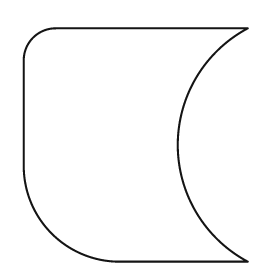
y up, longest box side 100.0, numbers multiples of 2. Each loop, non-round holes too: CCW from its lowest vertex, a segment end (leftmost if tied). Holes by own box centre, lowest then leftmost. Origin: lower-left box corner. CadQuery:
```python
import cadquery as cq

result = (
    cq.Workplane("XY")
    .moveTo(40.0, 0.0)
    .lineTo(96.0, 0.0)
    .threePointArc((66.0, 50.0), (96.0, 100.0))
    .lineTo(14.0, 100.0)
    .threePointArc((4.0, 96.0), (0.0, 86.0))
    .lineTo(0.0, 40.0)
    .threePointArc((12.0, 12.0), (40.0, 0.0))
    .close()
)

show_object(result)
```